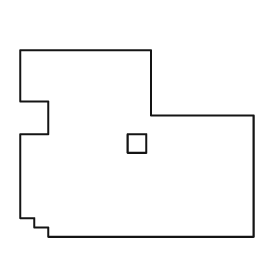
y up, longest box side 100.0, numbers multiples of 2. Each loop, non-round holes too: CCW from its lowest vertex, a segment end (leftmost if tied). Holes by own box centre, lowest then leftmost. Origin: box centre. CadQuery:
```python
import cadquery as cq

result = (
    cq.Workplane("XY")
    .moveTo(-38.0, -40.0)
    .lineTo(50.0, -40.0)
    .lineTo(50.0, 12.0)
    .lineTo(6.0, 12.0)
    .lineTo(6.0, 40.0)
    .lineTo(-50.0, 40.0)
    .lineTo(-50.0, 18.0)
    .lineTo(-38.0, 18.0)
    .lineTo(-38.0, 4.0)
    .lineTo(-50.0, 4.0)
    .lineTo(-50.0, -32.0)
    .lineTo(-44.0, -32.0)
    .lineTo(-44.0, -36.0)
    .lineTo(-38.0, -36.0)
    .close()
    .moveTo(-4.0, -4.0)
    .lineTo(4.0, -4.0)
    .lineTo(4.0, 4.0)
    .lineTo(-4.0, 4.0)
    .close()
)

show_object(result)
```